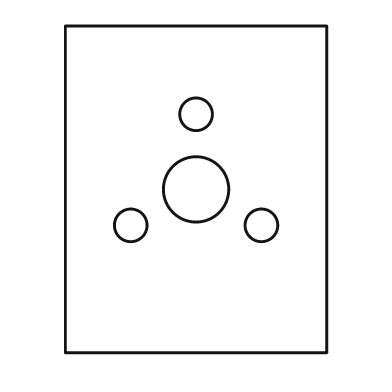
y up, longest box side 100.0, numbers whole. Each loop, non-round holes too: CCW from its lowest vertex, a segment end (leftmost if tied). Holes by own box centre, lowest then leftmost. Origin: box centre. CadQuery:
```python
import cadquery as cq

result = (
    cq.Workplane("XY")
    .moveTo(-40.0, -50.0)
    .lineTo(40.0, -50.0)
    .lineTo(40.0, 50.0)
    .lineTo(-40.0, 50.0)
    .close()
    .moveTo(-20.0, -11.0)
    .circle(5.0)
    .moveTo(20.0, -11.0)
    .circle(5.0)
    .moveTo(0.0, 0.0)
    .circle(10.0)
    .moveTo(0.0, 23.0)
    .circle(5.0)
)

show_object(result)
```